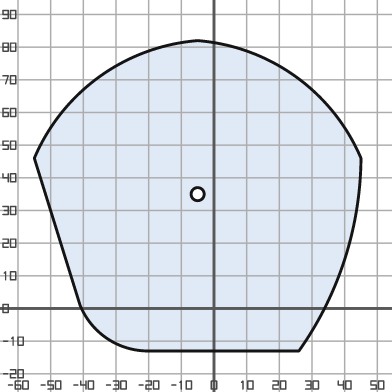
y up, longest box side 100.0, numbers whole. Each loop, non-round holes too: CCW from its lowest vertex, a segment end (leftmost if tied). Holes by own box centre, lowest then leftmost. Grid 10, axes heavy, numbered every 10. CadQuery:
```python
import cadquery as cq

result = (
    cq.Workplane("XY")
    .moveTo(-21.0, -13.0)
    .lineTo(26.0, -13.0)
    .threePointArc((40.0, 15.0), (45.0, 46.0))
    .threePointArc((25.0, 71.0), (-5.0, 82.0))
    .threePointArc((-35.0, 71.0), (-55.0, 46.0))
    .lineTo(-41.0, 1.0)
    .threePointArc((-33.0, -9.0), (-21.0, -13.0))
    .close()
    .moveTo(-5.0, 35.0)
    .circle(2.0)
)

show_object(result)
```